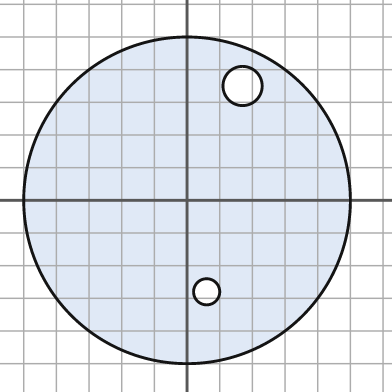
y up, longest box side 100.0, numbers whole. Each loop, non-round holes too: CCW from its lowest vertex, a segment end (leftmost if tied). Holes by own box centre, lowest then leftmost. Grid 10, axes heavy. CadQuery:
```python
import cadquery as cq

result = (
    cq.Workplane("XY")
    .moveTo(0.0, 0.0)
    .circle(50.0)
    .moveTo(6.0, -28.0)
    .circle(4.0)
    .moveTo(17.0, 35.0)
    .circle(6.0)
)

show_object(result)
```